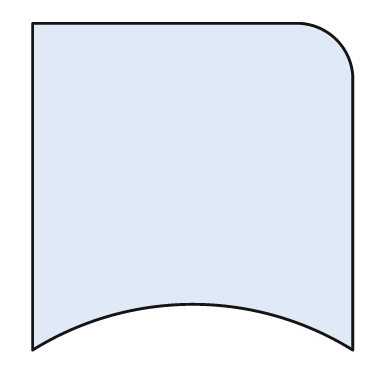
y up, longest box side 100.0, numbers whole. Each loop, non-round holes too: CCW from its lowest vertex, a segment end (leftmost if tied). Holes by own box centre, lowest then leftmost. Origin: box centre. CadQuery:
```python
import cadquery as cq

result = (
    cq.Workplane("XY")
    .moveTo(-49.0, -50.0)
    .threePointArc((0.0, -36.0), (49.0, -50.0))
    .lineTo(49.0, 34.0)
    .threePointArc((44.0, 45.0), (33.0, 50.0))
    .lineTo(-49.0, 50.0)
    .close()
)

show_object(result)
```